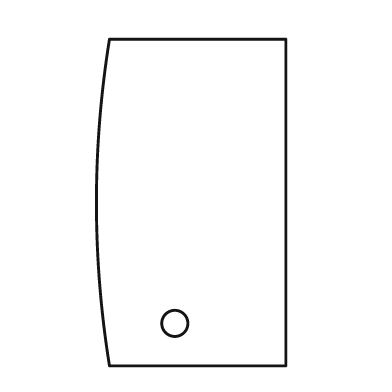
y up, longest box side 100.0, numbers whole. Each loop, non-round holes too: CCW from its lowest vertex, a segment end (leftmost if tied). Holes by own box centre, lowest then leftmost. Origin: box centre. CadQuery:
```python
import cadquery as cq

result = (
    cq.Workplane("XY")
    .moveTo(-25.0, -50.0)
    .lineTo(29.0, -50.0)
    .lineTo(29.0, 50.0)
    .lineTo(-25.0, 50.0)
    .threePointArc((-29.0, 0.0), (-25.0, -50.0))
    .close()
    .moveTo(-5.0, -37.0)
    .circle(4.0)
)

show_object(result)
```